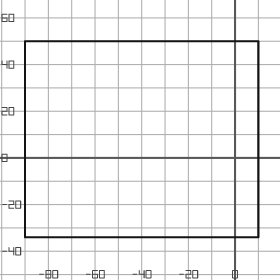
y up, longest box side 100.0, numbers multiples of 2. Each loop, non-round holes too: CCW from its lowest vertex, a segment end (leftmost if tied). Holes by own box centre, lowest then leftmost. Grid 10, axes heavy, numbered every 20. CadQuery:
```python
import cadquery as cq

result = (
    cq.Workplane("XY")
    .moveTo(-90.0, -34.0)
    .lineTo(10.0, -34.0)
    .lineTo(10.0, 50.0)
    .lineTo(-90.0, 50.0)
    .close()
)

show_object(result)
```